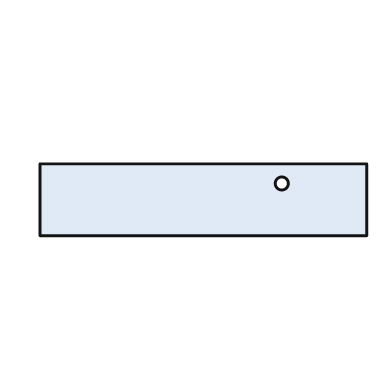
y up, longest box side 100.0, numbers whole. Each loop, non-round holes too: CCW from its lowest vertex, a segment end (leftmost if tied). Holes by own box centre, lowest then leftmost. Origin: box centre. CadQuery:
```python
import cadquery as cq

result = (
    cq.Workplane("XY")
    .moveTo(-50.0, -11.0)
    .lineTo(50.0, -11.0)
    .lineTo(50.0, 11.0)
    .lineTo(-50.0, 11.0)
    .close()
    .moveTo(24.0, 5.0)
    .circle(2.0)
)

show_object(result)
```